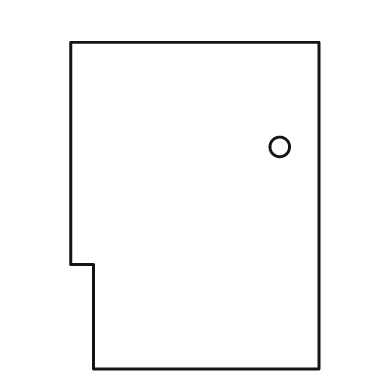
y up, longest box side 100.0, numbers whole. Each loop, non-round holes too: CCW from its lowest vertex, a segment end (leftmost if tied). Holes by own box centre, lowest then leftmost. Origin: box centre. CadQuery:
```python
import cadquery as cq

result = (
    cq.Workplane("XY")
    .moveTo(-31.0, -50.0)
    .lineTo(38.0, -50.0)
    .lineTo(38.0, 50.0)
    .lineTo(-38.0, 50.0)
    .lineTo(-38.0, -18.0)
    .lineTo(-31.0, -18.0)
    .close()
    .moveTo(26.0, 18.0)
    .circle(3.0)
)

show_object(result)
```